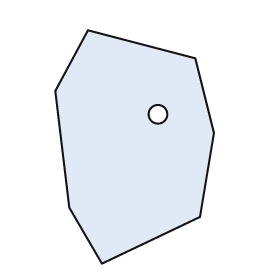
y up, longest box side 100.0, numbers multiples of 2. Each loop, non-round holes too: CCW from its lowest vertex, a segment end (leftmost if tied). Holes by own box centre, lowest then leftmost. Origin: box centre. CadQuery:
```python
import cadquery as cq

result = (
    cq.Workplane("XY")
    .moveTo(-14.0, -50.0)
    .lineTo(28.0, -30.0)
    .lineTo(34.0, 6.0)
    .lineTo(26.0, 38.0)
    .lineTo(-20.0, 50.0)
    .lineTo(-34.0, 24.0)
    .lineTo(-28.0, -26.0)
    .close()
    .moveTo(10.0, 14.0)
    .circle(4.0)
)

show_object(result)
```